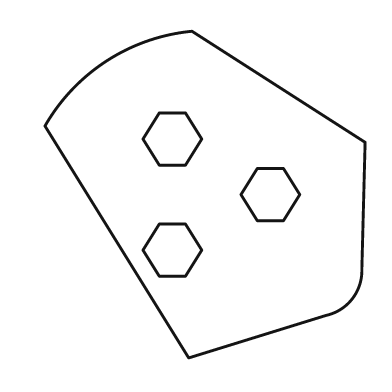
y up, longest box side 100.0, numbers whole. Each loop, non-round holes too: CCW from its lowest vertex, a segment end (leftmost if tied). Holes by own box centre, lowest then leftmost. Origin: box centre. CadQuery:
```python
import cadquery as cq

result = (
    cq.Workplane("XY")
    .moveTo(-5.0, -50.0)
    .lineTo(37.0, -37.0)
    .threePointArc((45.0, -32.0), (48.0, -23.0))
    .lineTo(49.0, 16.0)
    .lineTo(-4.0, 50.0)
    .threePointArc((-30.0, 41.0), (-49.0, 21.0))
    .close()
    .moveTo(-14.0, -25.0)
    .lineTo(-6.0, -25.0)
    .lineTo(-1.0, -17.0)
    .lineTo(-6.0, -9.0)
    .lineTo(-14.0, -9.0)
    .lineTo(-19.0, -17.0)
    .close()
    .moveTo(16.0, -8.0)
    .lineTo(24.0, -8.0)
    .lineTo(29.0, 0.0)
    .lineTo(24.0, 8.0)
    .lineTo(16.0, 8.0)
    .lineTo(11.0, 0.0)
    .close()
    .moveTo(-14.0, 9.0)
    .lineTo(-6.0, 9.0)
    .lineTo(-1.0, 17.0)
    .lineTo(-6.0, 25.0)
    .lineTo(-14.0, 25.0)
    .lineTo(-19.0, 17.0)
    .close()
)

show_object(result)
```